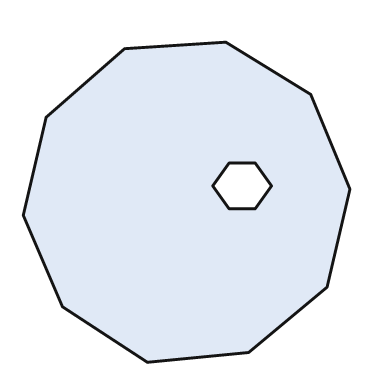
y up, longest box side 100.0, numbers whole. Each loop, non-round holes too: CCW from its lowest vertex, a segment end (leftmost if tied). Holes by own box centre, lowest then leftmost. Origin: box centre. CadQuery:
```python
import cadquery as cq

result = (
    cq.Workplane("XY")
    .moveTo(-12.0, -49.0)
    .lineTo(19.0, -46.0)
    .lineTo(43.0, -26.0)
    .lineTo(50.0, 4.0)
    .lineTo(38.0, 33.0)
    .lineTo(12.0, 49.0)
    .lineTo(-19.0, 47.0)
    .lineTo(-43.0, 26.0)
    .lineTo(-50.0, -4.0)
    .lineTo(-38.0, -32.0)
    .close()
    .moveTo(13.0, -2.0)
    .lineTo(21.0, -2.0)
    .lineTo(26.0, 5.0)
    .lineTo(21.0, 12.0)
    .lineTo(13.0, 12.0)
    .lineTo(8.0, 5.0)
    .close()
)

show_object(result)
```